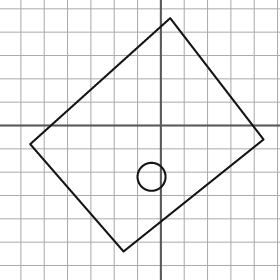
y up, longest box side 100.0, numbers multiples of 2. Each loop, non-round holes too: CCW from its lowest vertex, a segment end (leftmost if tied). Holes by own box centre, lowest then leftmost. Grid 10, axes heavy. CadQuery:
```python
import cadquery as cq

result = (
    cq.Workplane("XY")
    .moveTo(-16.0, -54.0)
    .lineTo(44.0, -6.0)
    .lineTo(4.0, 46.0)
    .lineTo(-56.0, -8.0)
    .close()
    .moveTo(-4.0, -22.0)
    .circle(6.0)
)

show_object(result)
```